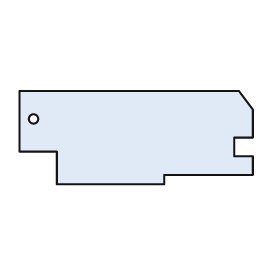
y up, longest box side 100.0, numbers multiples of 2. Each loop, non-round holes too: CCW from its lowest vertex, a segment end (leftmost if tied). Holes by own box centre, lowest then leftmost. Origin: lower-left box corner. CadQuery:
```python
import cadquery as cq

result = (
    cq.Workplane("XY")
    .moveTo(16.0, 0.0)
    .lineTo(62.0, 0.0)
    .lineTo(62.0, 4.0)
    .lineTo(100.0, 4.0)
    .lineTo(100.0, 12.0)
    .lineTo(92.0, 12.0)
    .lineTo(92.0, 20.0)
    .lineTo(100.0, 20.0)
    .lineTo(100.0, 32.0)
    .lineTo(94.0, 40.0)
    .lineTo(0.0, 40.0)
    .lineTo(0.0, 14.0)
    .lineTo(16.0, 14.0)
    .close()
    .moveTo(6.0, 28.0)
    .circle(2.0)
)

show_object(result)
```